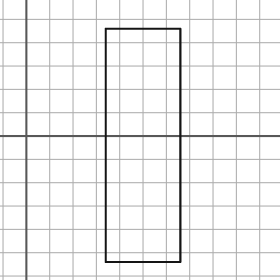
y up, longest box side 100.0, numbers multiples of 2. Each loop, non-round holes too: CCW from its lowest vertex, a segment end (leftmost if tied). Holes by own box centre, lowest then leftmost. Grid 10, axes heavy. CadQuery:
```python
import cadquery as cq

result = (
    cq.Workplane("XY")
    .moveTo(34.0, -54.0)
    .lineTo(66.0, -54.0)
    .lineTo(66.0, 46.0)
    .lineTo(34.0, 46.0)
    .close()
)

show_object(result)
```